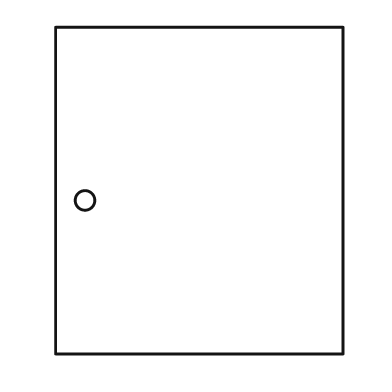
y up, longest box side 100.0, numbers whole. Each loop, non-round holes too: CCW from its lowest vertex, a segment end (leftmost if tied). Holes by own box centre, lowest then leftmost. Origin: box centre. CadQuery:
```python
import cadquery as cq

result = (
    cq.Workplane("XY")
    .moveTo(-44.0, -50.0)
    .lineTo(44.0, -50.0)
    .lineTo(44.0, 50.0)
    .lineTo(-44.0, 50.0)
    .close()
    .moveTo(-35.0, -3.0)
    .circle(3.0)
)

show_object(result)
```